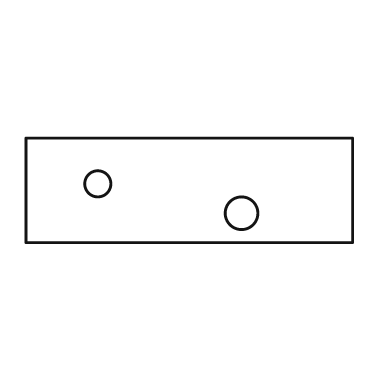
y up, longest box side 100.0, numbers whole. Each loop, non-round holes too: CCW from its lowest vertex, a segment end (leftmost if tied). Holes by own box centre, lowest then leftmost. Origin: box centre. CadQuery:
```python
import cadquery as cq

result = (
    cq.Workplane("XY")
    .moveTo(-50.0, -16.0)
    .lineTo(50.0, -16.0)
    .lineTo(50.0, 16.0)
    .lineTo(-50.0, 16.0)
    .close()
    .moveTo(16.0, -7.0)
    .circle(5.0)
    .moveTo(-28.0, 2.0)
    .circle(4.0)
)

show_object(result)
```